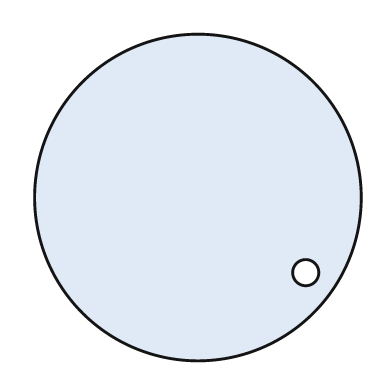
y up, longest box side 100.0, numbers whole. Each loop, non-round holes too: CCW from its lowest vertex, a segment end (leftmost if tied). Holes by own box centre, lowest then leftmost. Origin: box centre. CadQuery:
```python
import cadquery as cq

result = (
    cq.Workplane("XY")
    .moveTo(0.0, 0.0)
    .circle(50.0)
    .moveTo(33.0, -23.0)
    .circle(4.0)
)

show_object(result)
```